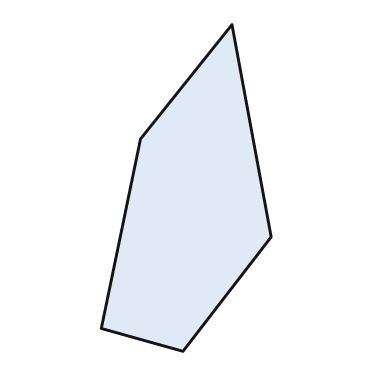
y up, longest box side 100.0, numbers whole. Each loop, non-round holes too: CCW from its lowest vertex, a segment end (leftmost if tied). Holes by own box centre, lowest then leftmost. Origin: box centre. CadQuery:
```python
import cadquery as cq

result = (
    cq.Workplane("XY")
    .moveTo(-1.0, -50.0)
    .lineTo(26.0, -15.0)
    .lineTo(14.0, 50.0)
    .lineTo(-14.0, 15.0)
    .lineTo(-26.0, -43.0)
    .close()
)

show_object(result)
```